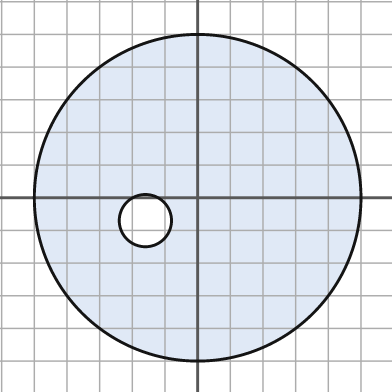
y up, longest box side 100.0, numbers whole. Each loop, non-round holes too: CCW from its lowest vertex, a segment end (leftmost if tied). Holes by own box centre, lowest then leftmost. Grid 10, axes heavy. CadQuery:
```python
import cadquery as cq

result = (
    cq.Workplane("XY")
    .moveTo(0.0, 0.0)
    .circle(50.0)
    .moveTo(-16.0, -7.0)
    .circle(8.0)
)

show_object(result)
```